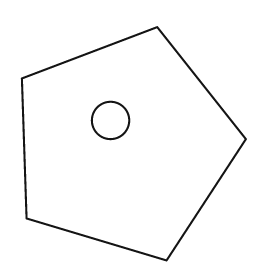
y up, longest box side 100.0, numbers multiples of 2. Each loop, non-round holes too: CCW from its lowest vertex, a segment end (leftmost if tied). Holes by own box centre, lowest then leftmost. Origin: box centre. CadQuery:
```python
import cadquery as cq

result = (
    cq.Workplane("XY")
    .moveTo(14.0, -50.0)
    .lineTo(48.0, 2.0)
    .lineTo(10.0, 50.0)
    .lineTo(-48.0, 28.0)
    .lineTo(-46.0, -32.0)
    .close()
    .moveTo(-10.0, 10.0)
    .circle(8.0)
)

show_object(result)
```